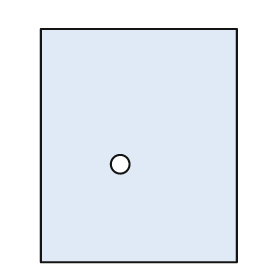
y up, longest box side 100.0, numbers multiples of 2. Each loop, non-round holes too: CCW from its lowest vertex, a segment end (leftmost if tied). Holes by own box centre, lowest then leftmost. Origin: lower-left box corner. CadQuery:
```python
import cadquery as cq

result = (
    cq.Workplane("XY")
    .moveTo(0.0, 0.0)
    .lineTo(84.0, 0.0)
    .lineTo(84.0, 100.0)
    .lineTo(0.0, 100.0)
    .close()
    .moveTo(34.0, 42.0)
    .circle(4.0)
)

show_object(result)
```